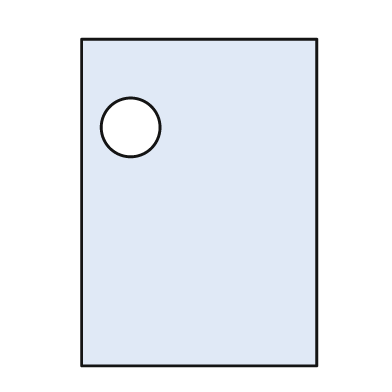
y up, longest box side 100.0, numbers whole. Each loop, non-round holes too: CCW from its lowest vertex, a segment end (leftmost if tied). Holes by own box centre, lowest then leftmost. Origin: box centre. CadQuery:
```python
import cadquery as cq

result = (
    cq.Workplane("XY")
    .moveTo(-36.0, -50.0)
    .lineTo(36.0, -50.0)
    .lineTo(36.0, 50.0)
    .lineTo(-36.0, 50.0)
    .close()
    .moveTo(-21.0, 23.0)
    .circle(9.0)
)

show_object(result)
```